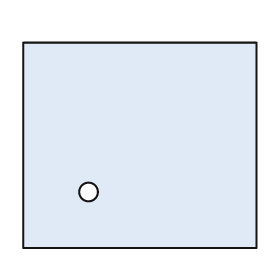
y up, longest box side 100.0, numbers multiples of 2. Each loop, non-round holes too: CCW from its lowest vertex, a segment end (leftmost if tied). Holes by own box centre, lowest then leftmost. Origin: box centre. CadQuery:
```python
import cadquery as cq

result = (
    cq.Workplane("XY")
    .moveTo(-50.0, -44.0)
    .lineTo(50.0, -44.0)
    .lineTo(50.0, 44.0)
    .lineTo(-50.0, 44.0)
    .close()
    .moveTo(-22.0, -20.0)
    .circle(4.0)
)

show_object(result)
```